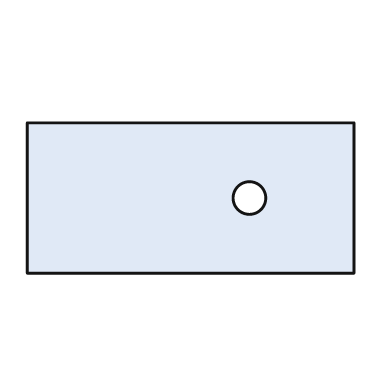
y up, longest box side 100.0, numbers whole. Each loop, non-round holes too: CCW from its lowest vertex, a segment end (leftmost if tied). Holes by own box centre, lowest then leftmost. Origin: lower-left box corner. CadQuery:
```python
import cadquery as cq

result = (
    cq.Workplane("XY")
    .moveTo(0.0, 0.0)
    .lineTo(100.0, 0.0)
    .lineTo(100.0, 46.0)
    .lineTo(0.0, 46.0)
    .close()
    .moveTo(68.0, 23.0)
    .circle(5.0)
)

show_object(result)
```